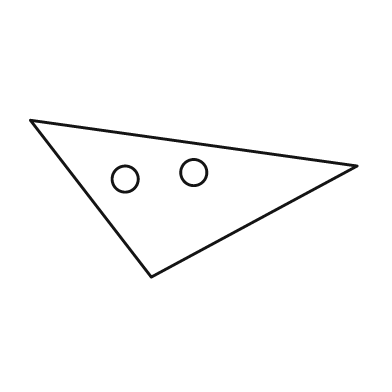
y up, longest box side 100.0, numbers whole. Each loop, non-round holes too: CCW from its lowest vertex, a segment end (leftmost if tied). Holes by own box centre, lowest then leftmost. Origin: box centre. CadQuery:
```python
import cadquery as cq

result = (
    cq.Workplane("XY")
    .moveTo(-13.0, -24.0)
    .lineTo(50.0, 10.0)
    .lineTo(-50.0, 24.0)
    .close()
    .moveTo(-21.0, 6.0)
    .circle(4.0)
    .moveTo(0.0, 8.0)
    .circle(4.0)
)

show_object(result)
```